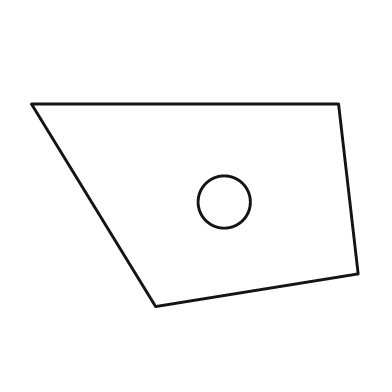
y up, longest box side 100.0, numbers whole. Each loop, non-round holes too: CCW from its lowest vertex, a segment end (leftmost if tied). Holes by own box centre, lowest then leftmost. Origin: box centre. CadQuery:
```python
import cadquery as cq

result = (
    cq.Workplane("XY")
    .moveTo(-12.0, -31.0)
    .lineTo(50.0, -21.0)
    .lineTo(44.0, 31.0)
    .lineTo(-50.0, 31.0)
    .close()
    .moveTo(9.0, 1.0)
    .circle(8.0)
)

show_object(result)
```